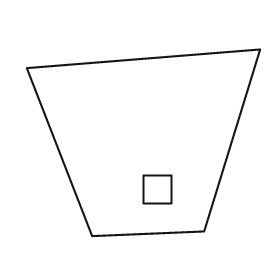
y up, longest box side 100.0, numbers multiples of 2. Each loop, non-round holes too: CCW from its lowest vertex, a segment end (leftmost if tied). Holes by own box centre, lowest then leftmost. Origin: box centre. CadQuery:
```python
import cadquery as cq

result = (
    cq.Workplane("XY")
    .moveTo(-22.0, -40.0)
    .lineTo(26.0, -38.0)
    .lineTo(50.0, 40.0)
    .lineTo(-50.0, 32.0)
    .close()
    .moveTo(0.0, -26.0)
    .lineTo(12.0, -26.0)
    .lineTo(12.0, -14.0)
    .lineTo(0.0, -14.0)
    .close()
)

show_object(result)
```